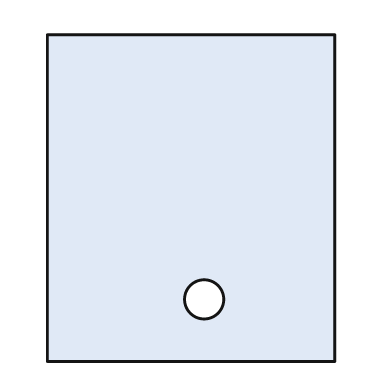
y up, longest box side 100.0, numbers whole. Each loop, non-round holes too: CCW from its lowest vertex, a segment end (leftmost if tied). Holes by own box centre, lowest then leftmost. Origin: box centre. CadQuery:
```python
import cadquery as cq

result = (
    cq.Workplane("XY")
    .moveTo(-44.0, -50.0)
    .lineTo(44.0, -50.0)
    .lineTo(44.0, 50.0)
    .lineTo(-44.0, 50.0)
    .close()
    .moveTo(4.0, -31.0)
    .circle(6.0)
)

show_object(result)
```